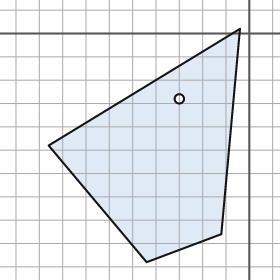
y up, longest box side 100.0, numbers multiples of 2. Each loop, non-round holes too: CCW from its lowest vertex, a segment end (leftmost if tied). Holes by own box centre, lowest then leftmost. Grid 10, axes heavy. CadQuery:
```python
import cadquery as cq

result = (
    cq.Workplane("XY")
    .moveTo(-44.0, -98.0)
    .lineTo(-12.0, -86.0)
    .lineTo(-4.0, 2.0)
    .lineTo(-86.0, -48.0)
    .close()
    .moveTo(-30.0, -28.0)
    .circle(2.0)
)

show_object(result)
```